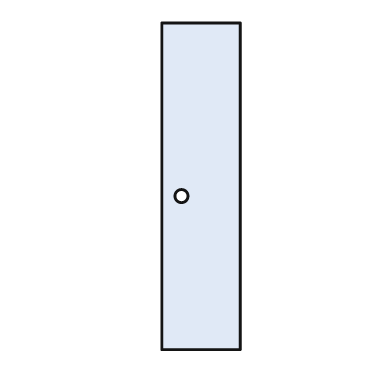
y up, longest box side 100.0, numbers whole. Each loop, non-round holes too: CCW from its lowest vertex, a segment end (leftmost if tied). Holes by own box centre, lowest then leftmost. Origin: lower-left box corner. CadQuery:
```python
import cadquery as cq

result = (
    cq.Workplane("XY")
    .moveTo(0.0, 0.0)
    .lineTo(24.0, 0.0)
    .lineTo(24.0, 100.0)
    .lineTo(0.0, 100.0)
    .close()
    .moveTo(6.0, 47.0)
    .circle(2.0)
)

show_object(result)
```